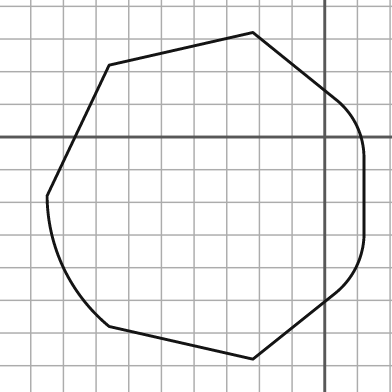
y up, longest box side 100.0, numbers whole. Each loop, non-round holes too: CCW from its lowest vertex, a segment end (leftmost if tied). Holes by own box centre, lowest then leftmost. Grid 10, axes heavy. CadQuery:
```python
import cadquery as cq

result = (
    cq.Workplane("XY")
    .moveTo(-22.0, -68.0)
    .lineTo(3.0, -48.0)
    .threePointArc((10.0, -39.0), (12.0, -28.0))
    .lineTo(12.0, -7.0)
    .threePointArc((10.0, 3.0), (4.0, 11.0))
    .lineTo(-22.0, 32.0)
    .lineTo(-66.0, 22.0)
    .lineTo(-85.0, -18.0)
    .threePointArc((-80.0, -40.0), (-66.0, -58.0))
    .close()
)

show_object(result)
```